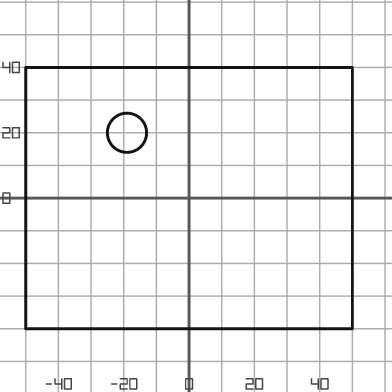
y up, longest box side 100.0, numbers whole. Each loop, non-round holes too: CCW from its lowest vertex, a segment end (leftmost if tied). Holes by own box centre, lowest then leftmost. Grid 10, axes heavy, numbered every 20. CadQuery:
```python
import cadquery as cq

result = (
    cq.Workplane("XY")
    .moveTo(-50.0, -40.0)
    .lineTo(50.0, -40.0)
    .lineTo(50.0, 40.0)
    .lineTo(-50.0, 40.0)
    .close()
    .moveTo(-19.0, 20.0)
    .circle(6.0)
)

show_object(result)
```